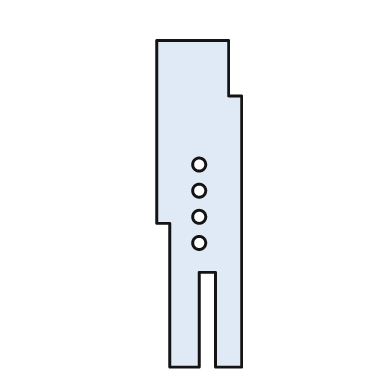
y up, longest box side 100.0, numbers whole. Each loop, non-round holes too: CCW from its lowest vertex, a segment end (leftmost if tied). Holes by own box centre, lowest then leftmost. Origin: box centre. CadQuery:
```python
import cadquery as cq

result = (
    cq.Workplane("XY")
    .moveTo(-9.0, -50.0)
    .lineTo(0.0, -50.0)
    .lineTo(0.0, -21.0)
    .lineTo(5.0, -21.0)
    .lineTo(5.0, -50.0)
    .lineTo(13.0, -50.0)
    .lineTo(13.0, 33.0)
    .lineTo(9.0, 33.0)
    .lineTo(9.0, 50.0)
    .lineTo(-13.0, 50.0)
    .lineTo(-13.0, -6.0)
    .lineTo(-9.0, -6.0)
    .close()
    .moveTo(0.0, -12.0)
    .circle(2.0)
    .moveTo(0.0, -4.0)
    .circle(2.0)
    .moveTo(0.0, 4.0)
    .circle(2.0)
    .moveTo(0.0, 12.0)
    .circle(2.0)
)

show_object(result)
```